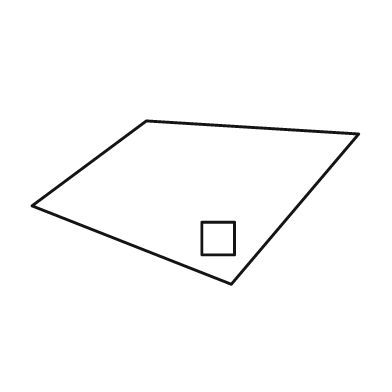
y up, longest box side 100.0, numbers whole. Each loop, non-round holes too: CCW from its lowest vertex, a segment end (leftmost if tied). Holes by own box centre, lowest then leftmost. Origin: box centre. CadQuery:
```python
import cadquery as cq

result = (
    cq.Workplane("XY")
    .moveTo(11.0, -25.0)
    .lineTo(50.0, 21.0)
    .lineTo(-15.0, 25.0)
    .lineTo(-50.0, -1.0)
    .close()
    .moveTo(2.0, -16.0)
    .lineTo(12.0, -16.0)
    .lineTo(12.0, -6.0)
    .lineTo(2.0, -6.0)
    .close()
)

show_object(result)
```